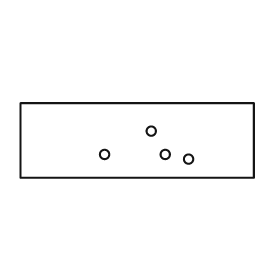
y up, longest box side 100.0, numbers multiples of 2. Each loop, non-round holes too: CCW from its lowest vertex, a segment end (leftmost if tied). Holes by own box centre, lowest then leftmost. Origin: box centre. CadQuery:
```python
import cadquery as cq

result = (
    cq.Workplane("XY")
    .moveTo(-50.0, -16.0)
    .lineTo(50.0, -16.0)
    .lineTo(50.0, 16.0)
    .lineTo(-50.0, 16.0)
    .close()
    .moveTo(22.0, -8.0)
    .circle(2.0)
    .moveTo(-14.0, -6.0)
    .circle(2.0)
    .moveTo(12.0, -6.0)
    .circle(2.0)
    .moveTo(6.0, 4.0)
    .circle(2.0)
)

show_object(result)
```